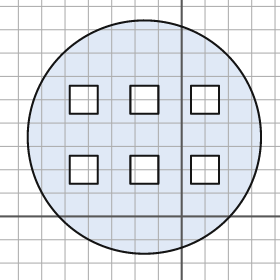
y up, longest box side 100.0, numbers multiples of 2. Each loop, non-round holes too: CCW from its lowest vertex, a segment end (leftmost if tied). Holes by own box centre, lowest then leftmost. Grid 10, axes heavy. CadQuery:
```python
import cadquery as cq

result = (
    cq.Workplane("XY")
    .moveTo(-16.0, 34.0)
    .circle(50.0)
    .moveTo(-48.0, 14.0)
    .lineTo(-36.0, 14.0)
    .lineTo(-36.0, 26.0)
    .lineTo(-48.0, 26.0)
    .close()
    .moveTo(-22.0, 14.0)
    .lineTo(-10.0, 14.0)
    .lineTo(-10.0, 26.0)
    .lineTo(-22.0, 26.0)
    .close()
    .moveTo(4.0, 14.0)
    .lineTo(16.0, 14.0)
    .lineTo(16.0, 26.0)
    .lineTo(4.0, 26.0)
    .close()
    .moveTo(-48.0, 44.0)
    .lineTo(-36.0, 44.0)
    .lineTo(-36.0, 56.0)
    .lineTo(-48.0, 56.0)
    .close()
    .moveTo(-22.0, 44.0)
    .lineTo(-10.0, 44.0)
    .lineTo(-10.0, 56.0)
    .lineTo(-22.0, 56.0)
    .close()
    .moveTo(4.0, 44.0)
    .lineTo(16.0, 44.0)
    .lineTo(16.0, 56.0)
    .lineTo(4.0, 56.0)
    .close()
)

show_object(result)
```